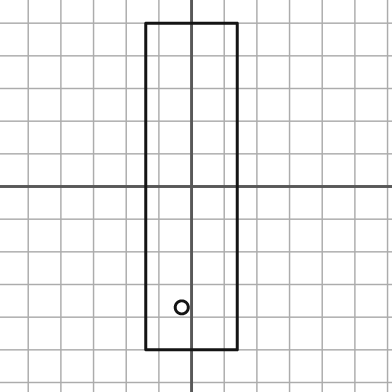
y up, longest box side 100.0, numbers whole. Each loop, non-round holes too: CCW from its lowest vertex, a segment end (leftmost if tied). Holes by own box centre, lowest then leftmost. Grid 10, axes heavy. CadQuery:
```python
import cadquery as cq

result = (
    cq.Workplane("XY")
    .moveTo(-14.0, -50.0)
    .lineTo(14.0, -50.0)
    .lineTo(14.0, 50.0)
    .lineTo(-14.0, 50.0)
    .close()
    .moveTo(-3.0, -37.0)
    .circle(2.0)
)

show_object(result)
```